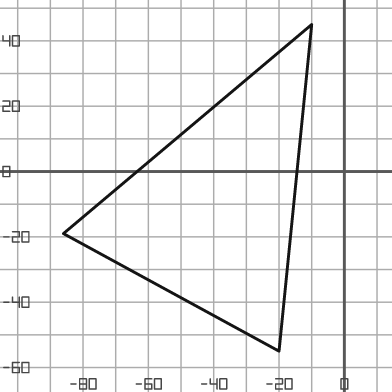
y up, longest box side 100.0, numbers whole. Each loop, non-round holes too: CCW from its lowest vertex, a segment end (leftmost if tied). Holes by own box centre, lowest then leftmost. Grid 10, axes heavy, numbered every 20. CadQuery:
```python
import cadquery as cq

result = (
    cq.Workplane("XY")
    .moveTo(-20.0, -55.0)
    .lineTo(-10.0, 45.0)
    .lineTo(-86.0, -19.0)
    .close()
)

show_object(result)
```